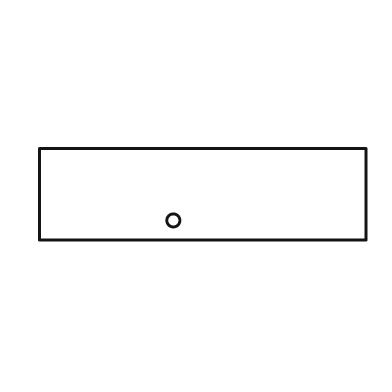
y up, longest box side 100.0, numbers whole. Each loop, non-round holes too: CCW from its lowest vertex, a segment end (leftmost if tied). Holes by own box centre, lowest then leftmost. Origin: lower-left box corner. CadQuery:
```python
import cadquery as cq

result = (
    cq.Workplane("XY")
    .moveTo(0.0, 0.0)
    .lineTo(100.0, 0.0)
    .lineTo(100.0, 28.0)
    .lineTo(0.0, 28.0)
    .close()
    .moveTo(41.0, 6.0)
    .circle(2.0)
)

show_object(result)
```